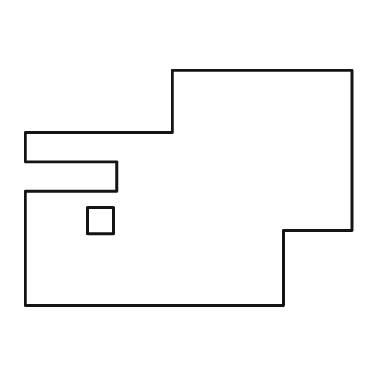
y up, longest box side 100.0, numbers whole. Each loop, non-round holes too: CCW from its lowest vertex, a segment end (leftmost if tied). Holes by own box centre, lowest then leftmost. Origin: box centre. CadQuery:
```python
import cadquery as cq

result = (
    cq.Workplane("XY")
    .moveTo(-50.0, -36.0)
    .lineTo(29.0, -36.0)
    .lineTo(29.0, -13.0)
    .lineTo(50.0, -13.0)
    .lineTo(50.0, 36.0)
    .lineTo(-5.0, 36.0)
    .lineTo(-5.0, 17.0)
    .lineTo(-50.0, 17.0)
    .lineTo(-50.0, 8.0)
    .lineTo(-22.0, 8.0)
    .lineTo(-22.0, -1.0)
    .lineTo(-50.0, -1.0)
    .close()
    .moveTo(-31.0, -14.0)
    .lineTo(-23.0, -14.0)
    .lineTo(-23.0, -6.0)
    .lineTo(-31.0, -6.0)
    .close()
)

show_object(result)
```